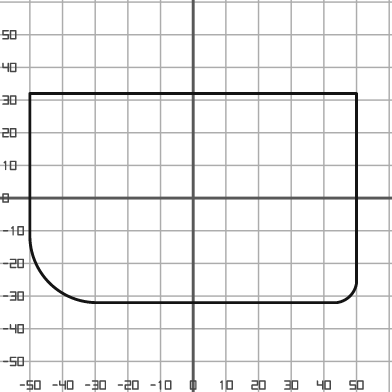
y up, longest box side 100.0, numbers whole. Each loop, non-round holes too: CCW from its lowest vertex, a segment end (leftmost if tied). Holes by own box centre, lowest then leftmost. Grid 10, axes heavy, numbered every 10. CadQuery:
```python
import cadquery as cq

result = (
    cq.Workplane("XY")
    .moveTo(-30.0, -32.0)
    .lineTo(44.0, -32.0)
    .threePointArc((48.0, -30.0), (50.0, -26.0))
    .lineTo(50.0, 32.0)
    .lineTo(-50.0, 32.0)
    .lineTo(-50.0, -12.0)
    .threePointArc((-44.0, -26.0), (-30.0, -32.0))
    .close()
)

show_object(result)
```